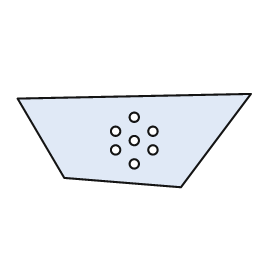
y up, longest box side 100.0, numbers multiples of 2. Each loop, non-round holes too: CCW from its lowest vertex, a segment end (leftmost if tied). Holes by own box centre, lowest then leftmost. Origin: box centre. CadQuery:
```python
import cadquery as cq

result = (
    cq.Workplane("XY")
    .moveTo(20.0, -20.0)
    .lineTo(50.0, 20.0)
    .lineTo(-50.0, 18.0)
    .lineTo(-30.0, -16.0)
    .close()
    .moveTo(0.0, -10.0)
    .circle(2.0)
    .moveTo(-8.0, -4.0)
    .circle(2.0)
    .moveTo(8.0, -4.0)
    .circle(2.0)
    .moveTo(0.0, 0.0)
    .circle(2.0)
    .moveTo(-8.0, 4.0)
    .circle(2.0)
    .moveTo(8.0, 4.0)
    .circle(2.0)
    .moveTo(0.0, 10.0)
    .circle(2.0)
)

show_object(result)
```